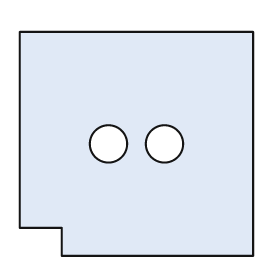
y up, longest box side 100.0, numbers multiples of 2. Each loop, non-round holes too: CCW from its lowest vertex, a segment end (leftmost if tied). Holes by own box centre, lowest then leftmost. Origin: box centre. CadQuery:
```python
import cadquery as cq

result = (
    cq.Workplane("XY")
    .moveTo(-32.0, -48.0)
    .lineTo(50.0, -48.0)
    .lineTo(50.0, 48.0)
    .lineTo(-50.0, 48.0)
    .lineTo(-50.0, -36.0)
    .lineTo(-32.0, -36.0)
    .close()
    .moveTo(-12.0, 0.0)
    .circle(8.0)
    .moveTo(12.0, 0.0)
    .circle(8.0)
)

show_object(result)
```